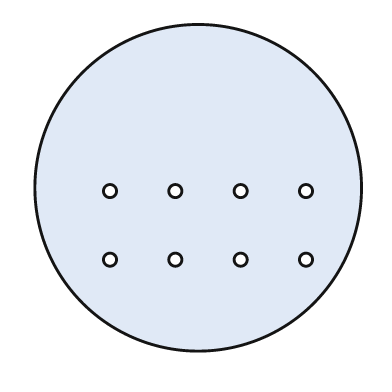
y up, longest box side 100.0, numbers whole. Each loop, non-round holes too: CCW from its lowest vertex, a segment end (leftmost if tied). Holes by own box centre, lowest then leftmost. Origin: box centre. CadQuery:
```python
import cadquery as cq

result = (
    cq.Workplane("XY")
    .moveTo(0.0, 0.0)
    .circle(50.0)
    .moveTo(-27.0, -22.0)
    .circle(2.0)
    .moveTo(-7.0, -22.0)
    .circle(2.0)
    .moveTo(13.0, -22.0)
    .circle(2.0)
    .moveTo(33.0, -22.0)
    .circle(2.0)
    .moveTo(-27.0, -1.0)
    .circle(2.0)
    .moveTo(-7.0, -1.0)
    .circle(2.0)
    .moveTo(13.0, -1.0)
    .circle(2.0)
    .moveTo(33.0, -1.0)
    .circle(2.0)
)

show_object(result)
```